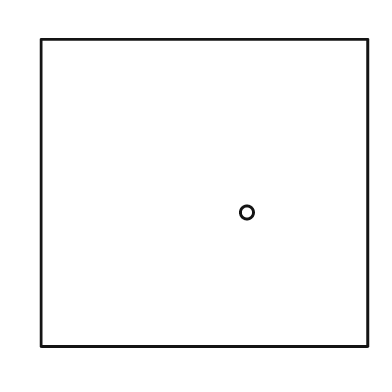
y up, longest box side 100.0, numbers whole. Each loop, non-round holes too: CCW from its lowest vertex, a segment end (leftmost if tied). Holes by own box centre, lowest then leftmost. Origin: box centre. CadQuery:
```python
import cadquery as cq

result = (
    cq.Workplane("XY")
    .moveTo(-50.0, -47.0)
    .lineTo(50.0, -47.0)
    .lineTo(50.0, 47.0)
    .lineTo(-50.0, 47.0)
    .close()
    .moveTo(13.0, -6.0)
    .circle(2.0)
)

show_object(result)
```